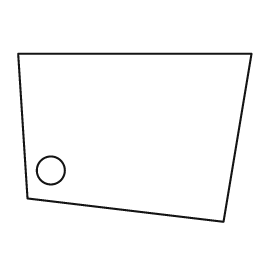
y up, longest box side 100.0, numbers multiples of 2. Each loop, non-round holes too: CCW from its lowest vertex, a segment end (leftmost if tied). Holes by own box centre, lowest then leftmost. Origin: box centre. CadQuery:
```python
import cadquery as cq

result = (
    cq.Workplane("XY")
    .moveTo(38.0, -36.0)
    .lineTo(50.0, 36.0)
    .lineTo(-50.0, 36.0)
    .lineTo(-46.0, -26.0)
    .close()
    .moveTo(-36.0, -14.0)
    .circle(6.0)
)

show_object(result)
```